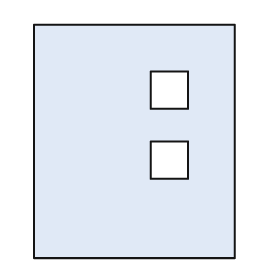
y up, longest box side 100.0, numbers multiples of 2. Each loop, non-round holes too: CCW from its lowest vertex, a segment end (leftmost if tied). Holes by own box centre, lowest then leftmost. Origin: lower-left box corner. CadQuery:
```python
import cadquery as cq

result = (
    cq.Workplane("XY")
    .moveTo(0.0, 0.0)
    .lineTo(86.0, 0.0)
    .lineTo(86.0, 100.0)
    .lineTo(0.0, 100.0)
    .close()
    .moveTo(50.0, 34.0)
    .lineTo(66.0, 34.0)
    .lineTo(66.0, 50.0)
    .lineTo(50.0, 50.0)
    .close()
    .moveTo(50.0, 64.0)
    .lineTo(66.0, 64.0)
    .lineTo(66.0, 80.0)
    .lineTo(50.0, 80.0)
    .close()
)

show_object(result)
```